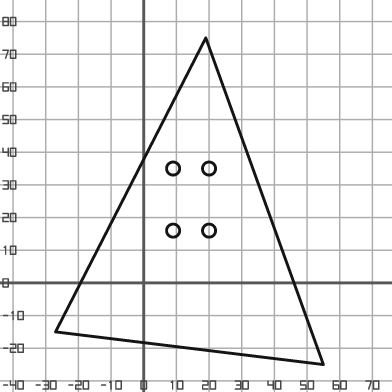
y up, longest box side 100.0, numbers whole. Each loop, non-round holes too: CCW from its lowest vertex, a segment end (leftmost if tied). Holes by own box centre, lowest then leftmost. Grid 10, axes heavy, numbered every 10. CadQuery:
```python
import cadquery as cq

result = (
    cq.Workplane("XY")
    .moveTo(55.0, -25.0)
    .lineTo(19.0, 75.0)
    .lineTo(-27.0, -15.0)
    .close()
    .moveTo(9.0, 16.0)
    .circle(2.0)
    .moveTo(20.0, 16.0)
    .circle(2.0)
    .moveTo(9.0, 35.0)
    .circle(2.0)
    .moveTo(20.0, 35.0)
    .circle(2.0)
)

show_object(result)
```